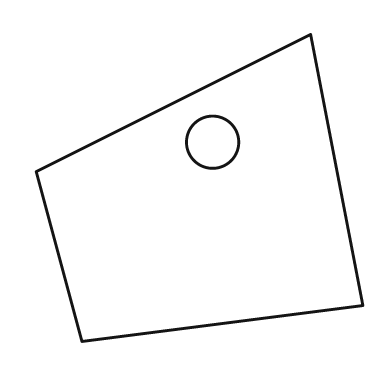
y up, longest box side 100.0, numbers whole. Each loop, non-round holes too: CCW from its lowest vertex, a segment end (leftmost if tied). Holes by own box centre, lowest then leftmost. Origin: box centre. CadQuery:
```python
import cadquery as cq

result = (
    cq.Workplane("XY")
    .moveTo(-36.0, -47.0)
    .lineTo(50.0, -36.0)
    .lineTo(34.0, 47.0)
    .lineTo(-50.0, 5.0)
    .close()
    .moveTo(4.0, 14.0)
    .circle(8.0)
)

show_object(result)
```